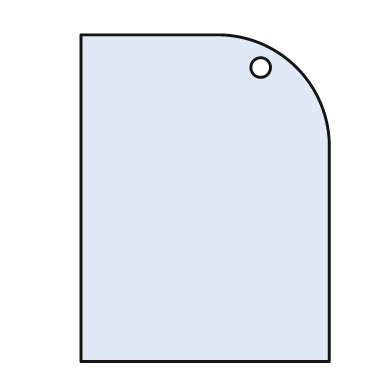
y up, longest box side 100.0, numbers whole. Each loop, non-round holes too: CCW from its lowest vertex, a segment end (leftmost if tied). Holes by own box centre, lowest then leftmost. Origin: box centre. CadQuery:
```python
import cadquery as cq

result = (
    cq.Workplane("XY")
    .moveTo(-38.0, -50.0)
    .lineTo(38.0, -50.0)
    .lineTo(38.0, 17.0)
    .threePointArc((28.0, 40.0), (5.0, 50.0))
    .lineTo(-38.0, 50.0)
    .close()
    .moveTo(17.0, 40.0)
    .circle(3.0)
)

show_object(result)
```